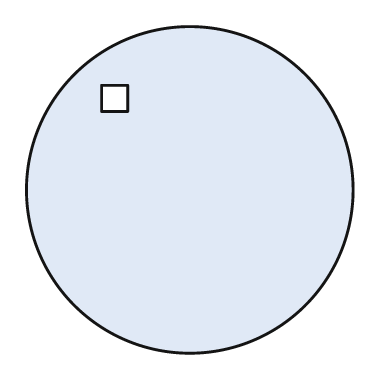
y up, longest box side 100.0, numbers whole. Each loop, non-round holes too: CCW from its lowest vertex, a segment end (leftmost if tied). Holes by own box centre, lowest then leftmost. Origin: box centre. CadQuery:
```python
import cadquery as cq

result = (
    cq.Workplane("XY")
    .moveTo(0.0, 0.0)
    .circle(50.0)
    .moveTo(-27.0, 24.0)
    .lineTo(-19.0, 24.0)
    .lineTo(-19.0, 32.0)
    .lineTo(-27.0, 32.0)
    .close()
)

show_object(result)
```